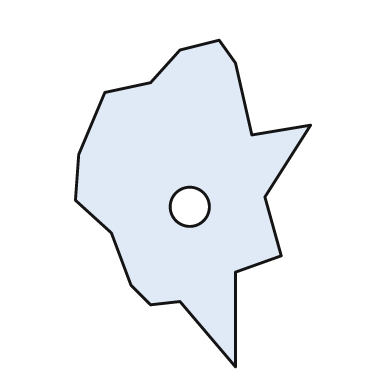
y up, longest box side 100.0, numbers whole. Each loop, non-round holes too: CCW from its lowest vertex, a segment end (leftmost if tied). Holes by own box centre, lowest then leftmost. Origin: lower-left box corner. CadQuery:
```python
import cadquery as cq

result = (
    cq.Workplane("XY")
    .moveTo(49.0, 0.0)
    .lineTo(49.0, 29.0)
    .lineTo(63.0, 34.0)
    .lineTo(58.0, 52.0)
    .lineTo(72.0, 74.0)
    .lineTo(54.0, 71.0)
    .lineTo(49.0, 93.0)
    .lineTo(44.0, 100.0)
    .lineTo(32.0, 97.0)
    .lineTo(23.0, 87.0)
    .lineTo(9.0, 84.0)
    .lineTo(1.0, 65.0)
    .lineTo(0.0, 51.0)
    .lineTo(11.0, 41.0)
    .lineTo(17.0, 25.0)
    .lineTo(23.0, 19.0)
    .lineTo(32.0, 20.0)
    .close()
    .moveTo(35.0, 49.0)
    .circle(6.0)
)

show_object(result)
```